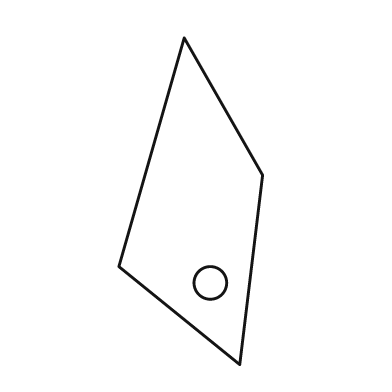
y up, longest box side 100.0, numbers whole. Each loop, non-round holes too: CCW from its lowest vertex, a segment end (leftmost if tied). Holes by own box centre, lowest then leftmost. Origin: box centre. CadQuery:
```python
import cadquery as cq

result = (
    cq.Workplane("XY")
    .moveTo(15.0, -50.0)
    .lineTo(22.0, 8.0)
    .lineTo(-2.0, 50.0)
    .lineTo(-22.0, -20.0)
    .close()
    .moveTo(6.0, -25.0)
    .circle(5.0)
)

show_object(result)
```